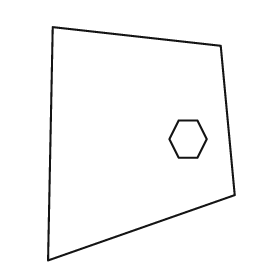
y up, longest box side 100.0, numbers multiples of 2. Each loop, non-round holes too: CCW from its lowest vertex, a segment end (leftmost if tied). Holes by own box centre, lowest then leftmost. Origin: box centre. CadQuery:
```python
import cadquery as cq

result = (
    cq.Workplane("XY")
    .moveTo(-40.0, -50.0)
    .lineTo(40.0, -22.0)
    .lineTo(34.0, 42.0)
    .lineTo(-38.0, 50.0)
    .close()
    .moveTo(16.0, -6.0)
    .lineTo(24.0, -6.0)
    .lineTo(28.0, 2.0)
    .lineTo(24.0, 10.0)
    .lineTo(16.0, 10.0)
    .lineTo(12.0, 2.0)
    .close()
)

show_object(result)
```